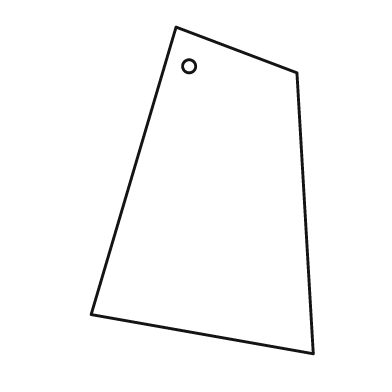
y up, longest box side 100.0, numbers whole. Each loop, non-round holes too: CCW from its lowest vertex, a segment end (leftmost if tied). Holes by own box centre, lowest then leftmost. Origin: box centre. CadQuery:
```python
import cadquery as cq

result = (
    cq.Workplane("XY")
    .moveTo(34.0, -50.0)
    .lineTo(29.0, 36.0)
    .lineTo(-8.0, 50.0)
    .lineTo(-34.0, -38.0)
    .close()
    .moveTo(-4.0, 38.0)
    .circle(2.0)
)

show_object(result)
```